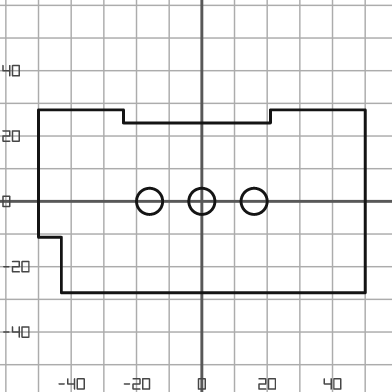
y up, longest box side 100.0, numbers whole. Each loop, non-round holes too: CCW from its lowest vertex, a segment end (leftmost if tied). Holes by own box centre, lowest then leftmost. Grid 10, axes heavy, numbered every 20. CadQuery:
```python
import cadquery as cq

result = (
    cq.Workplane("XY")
    .moveTo(-43.0, -28.0)
    .lineTo(50.0, -28.0)
    .lineTo(50.0, 28.0)
    .lineTo(21.0, 28.0)
    .lineTo(21.0, 24.0)
    .lineTo(-24.0, 24.0)
    .lineTo(-24.0, 28.0)
    .lineTo(-50.0, 28.0)
    .lineTo(-50.0, -11.0)
    .lineTo(-43.0, -11.0)
    .close()
    .moveTo(-16.0, 0.0)
    .circle(4.0)
    .moveTo(0.0, 0.0)
    .circle(4.0)
    .moveTo(16.0, 0.0)
    .circle(4.0)
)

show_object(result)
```